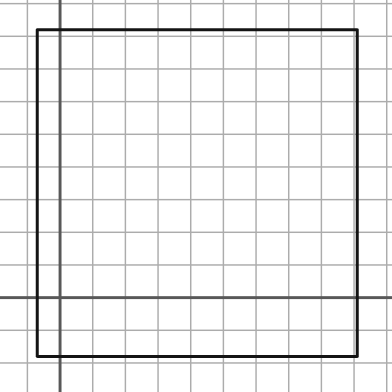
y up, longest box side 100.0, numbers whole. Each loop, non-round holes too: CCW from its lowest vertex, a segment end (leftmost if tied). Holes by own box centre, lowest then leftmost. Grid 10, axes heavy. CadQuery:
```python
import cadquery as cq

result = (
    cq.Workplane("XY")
    .moveTo(-7.0, -18.0)
    .lineTo(91.0, -18.0)
    .lineTo(91.0, 82.0)
    .lineTo(-7.0, 82.0)
    .close()
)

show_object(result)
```